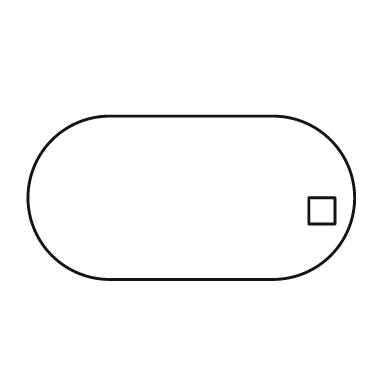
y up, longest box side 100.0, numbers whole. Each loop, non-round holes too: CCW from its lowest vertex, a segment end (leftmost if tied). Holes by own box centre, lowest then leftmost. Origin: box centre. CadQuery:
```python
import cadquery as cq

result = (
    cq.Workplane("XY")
    .moveTo(-25.0, -25.0)
    .lineTo(25.0, -25.0)
    .threePointArc((50.0, 0.0), (25.0, 25.0))
    .lineTo(-25.0, 25.0)
    .threePointArc((-50.0, 0.0), (-25.0, -25.0))
    .close()
    .moveTo(36.0, -8.0)
    .lineTo(44.0, -8.0)
    .lineTo(44.0, 0.0)
    .lineTo(36.0, 0.0)
    .close()
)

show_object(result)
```